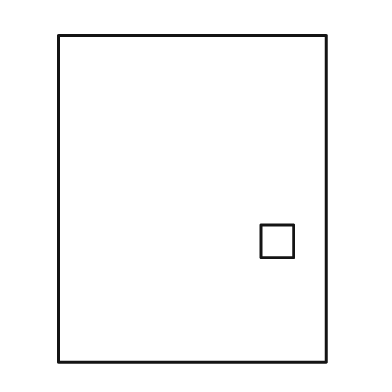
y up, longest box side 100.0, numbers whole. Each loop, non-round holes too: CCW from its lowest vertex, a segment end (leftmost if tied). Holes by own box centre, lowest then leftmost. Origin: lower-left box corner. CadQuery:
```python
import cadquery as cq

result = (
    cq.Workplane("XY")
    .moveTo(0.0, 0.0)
    .lineTo(82.0, 0.0)
    .lineTo(82.0, 100.0)
    .lineTo(0.0, 100.0)
    .close()
    .moveTo(62.0, 32.0)
    .lineTo(72.0, 32.0)
    .lineTo(72.0, 42.0)
    .lineTo(62.0, 42.0)
    .close()
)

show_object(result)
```